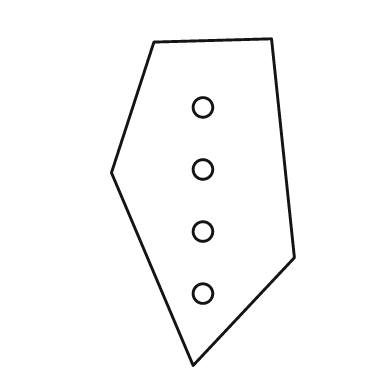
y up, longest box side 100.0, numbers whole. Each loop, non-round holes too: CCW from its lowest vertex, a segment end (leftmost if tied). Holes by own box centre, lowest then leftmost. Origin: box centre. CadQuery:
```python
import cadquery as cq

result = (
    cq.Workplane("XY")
    .moveTo(-3.0, -50.0)
    .lineTo(28.0, -17.0)
    .lineTo(21.0, 50.0)
    .lineTo(-15.0, 49.0)
    .lineTo(-28.0, 9.0)
    .close()
    .moveTo(0.0, -28.0)
    .circle(3.0)
    .moveTo(0.0, -9.0)
    .circle(3.0)
    .moveTo(0.0, 10.0)
    .circle(3.0)
    .moveTo(0.0, 29.0)
    .circle(3.0)
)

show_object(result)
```